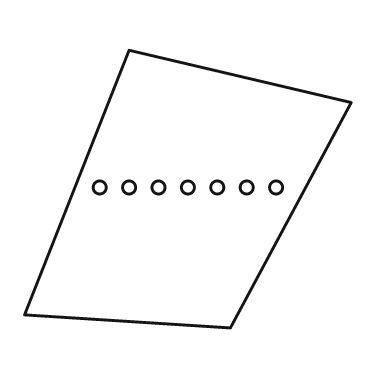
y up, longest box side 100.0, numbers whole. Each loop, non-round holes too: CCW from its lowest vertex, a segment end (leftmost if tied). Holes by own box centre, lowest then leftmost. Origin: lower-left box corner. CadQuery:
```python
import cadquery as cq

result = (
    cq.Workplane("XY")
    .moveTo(63.0, 0.0)
    .lineTo(100.0, 69.0)
    .lineTo(32.0, 85.0)
    .lineTo(0.0, 4.0)
    .close()
    .moveTo(23.0, 43.0)
    .circle(2.0)
    .moveTo(32.0, 43.0)
    .circle(2.0)
    .moveTo(41.0, 43.0)
    .circle(2.0)
    .moveTo(50.0, 43.0)
    .circle(2.0)
    .moveTo(59.0, 43.0)
    .circle(2.0)
    .moveTo(68.0, 43.0)
    .circle(2.0)
    .moveTo(77.0, 43.0)
    .circle(2.0)
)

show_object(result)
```